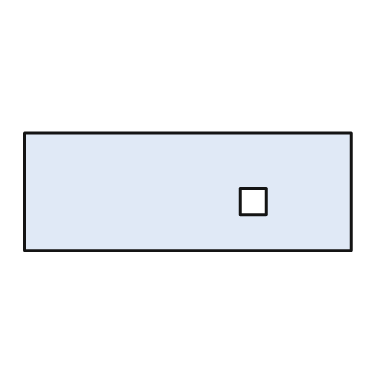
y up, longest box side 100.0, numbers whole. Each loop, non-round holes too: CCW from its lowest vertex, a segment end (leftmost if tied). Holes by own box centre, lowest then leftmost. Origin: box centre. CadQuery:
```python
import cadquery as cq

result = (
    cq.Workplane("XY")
    .moveTo(-50.0, -18.0)
    .lineTo(50.0, -18.0)
    .lineTo(50.0, 18.0)
    .lineTo(-50.0, 18.0)
    .close()
    .moveTo(16.0, -7.0)
    .lineTo(24.0, -7.0)
    .lineTo(24.0, 1.0)
    .lineTo(16.0, 1.0)
    .close()
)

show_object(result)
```